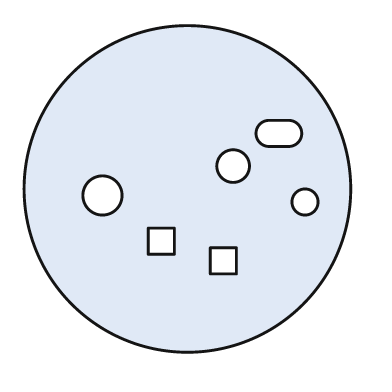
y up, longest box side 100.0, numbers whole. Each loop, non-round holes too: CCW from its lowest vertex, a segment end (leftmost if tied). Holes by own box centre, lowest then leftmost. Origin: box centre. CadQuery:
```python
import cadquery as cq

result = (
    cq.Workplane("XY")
    .moveTo(0.0, 0.0)
    .circle(50.0)
    .moveTo(7.0, -26.0)
    .lineTo(15.0, -26.0)
    .lineTo(15.0, -18.0)
    .lineTo(7.0, -18.0)
    .close()
    .moveTo(-12.0, -20.0)
    .lineTo(-4.0, -20.0)
    .lineTo(-4.0, -12.0)
    .lineTo(-12.0, -12.0)
    .close()
    .moveTo(36.0, -4.0)
    .circle(4.0)
    .moveTo(-26.0, -2.0)
    .circle(6.0)
    .moveTo(14.0, 7.0)
    .circle(5.0)
    .moveTo(25.0, 13.0)
    .lineTo(31.0, 13.0)
    .threePointArc((35.0, 17.0), (31.0, 21.0))
    .lineTo(25.0, 21.0)
    .threePointArc((21.0, 17.0), (25.0, 13.0))
    .close()
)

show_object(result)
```